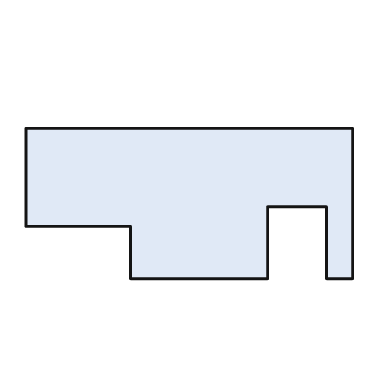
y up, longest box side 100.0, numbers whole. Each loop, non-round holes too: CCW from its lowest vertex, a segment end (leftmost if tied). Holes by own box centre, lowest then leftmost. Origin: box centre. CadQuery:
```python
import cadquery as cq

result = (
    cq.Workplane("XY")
    .moveTo(-18.0, -23.0)
    .lineTo(24.0, -23.0)
    .lineTo(24.0, -1.0)
    .lineTo(42.0, -1.0)
    .lineTo(42.0, -23.0)
    .lineTo(50.0, -23.0)
    .lineTo(50.0, 23.0)
    .lineTo(-50.0, 23.0)
    .lineTo(-50.0, -7.0)
    .lineTo(-18.0, -7.0)
    .close()
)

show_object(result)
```